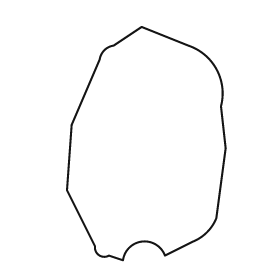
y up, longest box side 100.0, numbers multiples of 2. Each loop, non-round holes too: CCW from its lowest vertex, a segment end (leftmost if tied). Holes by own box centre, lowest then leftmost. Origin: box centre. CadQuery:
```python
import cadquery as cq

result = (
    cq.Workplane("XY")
    .moveTo(-10.0, -50.0)
    .threePointArc((-2.0, -42.0), (8.0, -48.0))
    .lineTo(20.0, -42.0)
    .threePointArc((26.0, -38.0), (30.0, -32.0))
    .lineTo(34.0, -2.0)
    .lineTo(32.0, 16.0)
    .threePointArc((30.0, 32.0), (18.0, 42.0))
    .lineTo(-2.0, 50.0)
    .lineTo(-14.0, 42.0)
    .threePointArc((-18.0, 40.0), (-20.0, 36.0))
    .lineTo(-32.0, 8.0)
    .lineTo(-34.0, -20.0)
    .lineTo(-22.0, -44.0)
    .threePointArc((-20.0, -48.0), (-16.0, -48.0))
    .close()
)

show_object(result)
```